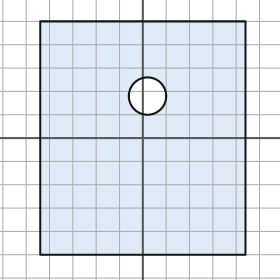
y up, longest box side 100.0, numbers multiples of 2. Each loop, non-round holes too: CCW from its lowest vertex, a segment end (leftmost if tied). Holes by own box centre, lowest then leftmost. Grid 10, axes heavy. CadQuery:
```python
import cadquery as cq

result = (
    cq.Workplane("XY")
    .moveTo(-44.0, -50.0)
    .lineTo(44.0, -50.0)
    .lineTo(44.0, 50.0)
    .lineTo(-44.0, 50.0)
    .close()
    .moveTo(2.0, 18.0)
    .circle(8.0)
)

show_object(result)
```